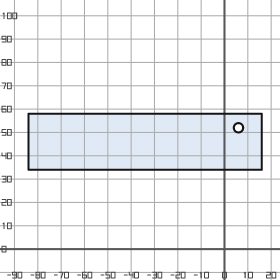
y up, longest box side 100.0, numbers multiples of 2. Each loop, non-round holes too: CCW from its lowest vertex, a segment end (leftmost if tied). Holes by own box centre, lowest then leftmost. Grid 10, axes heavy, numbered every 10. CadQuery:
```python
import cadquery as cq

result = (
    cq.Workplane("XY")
    .moveTo(-84.0, 34.0)
    .lineTo(16.0, 34.0)
    .lineTo(16.0, 58.0)
    .lineTo(-84.0, 58.0)
    .close()
    .moveTo(6.0, 52.0)
    .circle(2.0)
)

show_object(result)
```